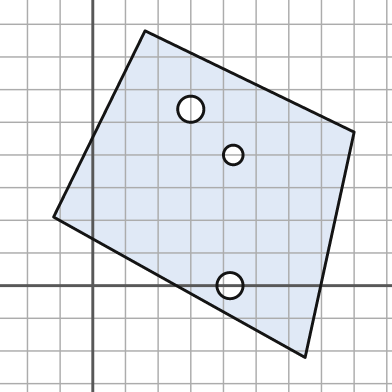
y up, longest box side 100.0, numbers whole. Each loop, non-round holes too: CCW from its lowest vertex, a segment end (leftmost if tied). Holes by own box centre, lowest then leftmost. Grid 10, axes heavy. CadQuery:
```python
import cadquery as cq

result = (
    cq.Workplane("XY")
    .moveTo(65.0, -22.0)
    .lineTo(80.0, 47.0)
    .lineTo(16.0, 78.0)
    .lineTo(-12.0, 21.0)
    .close()
    .moveTo(42.0, 0.0)
    .circle(4.0)
    .moveTo(43.0, 40.0)
    .circle(3.0)
    .moveTo(30.0, 54.0)
    .circle(4.0)
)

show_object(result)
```